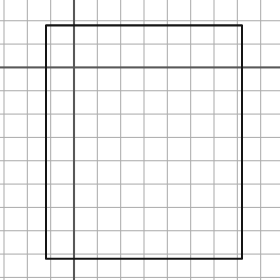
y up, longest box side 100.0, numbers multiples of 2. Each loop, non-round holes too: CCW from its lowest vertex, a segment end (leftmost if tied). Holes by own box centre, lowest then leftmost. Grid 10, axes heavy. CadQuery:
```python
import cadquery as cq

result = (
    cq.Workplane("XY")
    .moveTo(-12.0, -82.0)
    .lineTo(72.0, -82.0)
    .lineTo(72.0, 18.0)
    .lineTo(-12.0, 18.0)
    .close()
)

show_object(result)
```